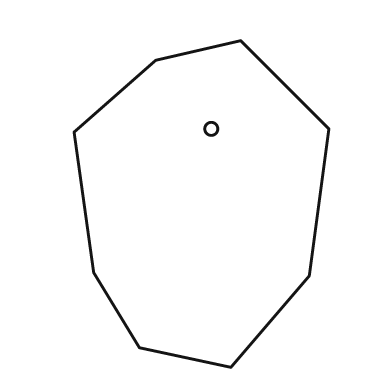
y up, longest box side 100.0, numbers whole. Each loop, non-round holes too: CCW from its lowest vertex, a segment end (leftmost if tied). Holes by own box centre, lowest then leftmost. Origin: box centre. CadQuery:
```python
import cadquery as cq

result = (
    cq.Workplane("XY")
    .moveTo(9.0, -50.0)
    .lineTo(33.0, -22.0)
    .lineTo(39.0, 23.0)
    .lineTo(12.0, 50.0)
    .lineTo(-14.0, 44.0)
    .lineTo(-39.0, 22.0)
    .lineTo(-33.0, -21.0)
    .lineTo(-19.0, -44.0)
    .close()
    .moveTo(3.0, 23.0)
    .circle(2.0)
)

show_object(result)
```